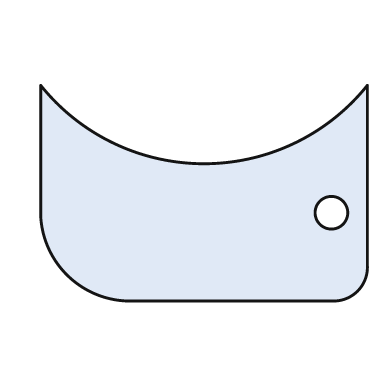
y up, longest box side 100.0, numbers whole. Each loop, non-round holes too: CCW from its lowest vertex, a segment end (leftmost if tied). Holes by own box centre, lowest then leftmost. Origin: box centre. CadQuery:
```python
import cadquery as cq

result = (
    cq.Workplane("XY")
    .moveTo(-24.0, -33.0)
    .lineTo(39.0, -33.0)
    .threePointArc((47.0, -30.0), (50.0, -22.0))
    .lineTo(50.0, 33.0)
    .threePointArc((0.0, 9.0), (-50.0, 33.0))
    .lineTo(-50.0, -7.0)
    .threePointArc((-42.0, -25.0), (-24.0, -33.0))
    .close()
    .moveTo(39.0, -6.0)
    .circle(5.0)
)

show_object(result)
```